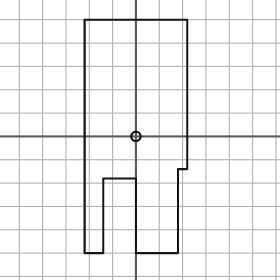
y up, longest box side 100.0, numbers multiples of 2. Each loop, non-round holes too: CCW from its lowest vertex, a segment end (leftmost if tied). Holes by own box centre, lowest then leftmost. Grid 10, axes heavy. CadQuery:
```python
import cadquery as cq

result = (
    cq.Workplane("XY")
    .moveTo(-22.0, -50.0)
    .lineTo(-14.0, -50.0)
    .lineTo(-14.0, -18.0)
    .lineTo(0.0, -18.0)
    .lineTo(0.0, -50.0)
    .lineTo(18.0, -50.0)
    .lineTo(18.0, -14.0)
    .lineTo(22.0, -14.0)
    .lineTo(22.0, 50.0)
    .lineTo(-22.0, 50.0)
    .close()
    .moveTo(0.0, 0.0)
    .circle(2.0)
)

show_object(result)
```